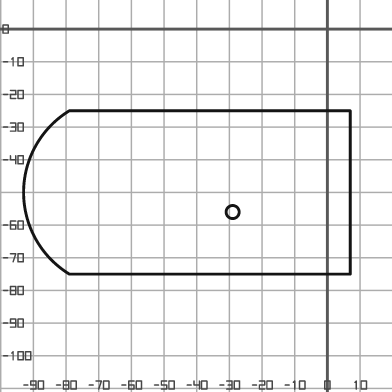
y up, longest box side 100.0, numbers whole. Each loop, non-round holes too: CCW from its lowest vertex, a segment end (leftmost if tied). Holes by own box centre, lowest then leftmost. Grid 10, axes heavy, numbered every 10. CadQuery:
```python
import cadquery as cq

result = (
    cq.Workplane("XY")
    .moveTo(-79.0, -75.0)
    .lineTo(7.0, -75.0)
    .lineTo(7.0, -25.0)
    .lineTo(-79.0, -25.0)
    .threePointArc((-93.0, -50.0), (-79.0, -75.0))
    .close()
    .moveTo(-29.0, -56.0)
    .circle(2.0)
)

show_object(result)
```